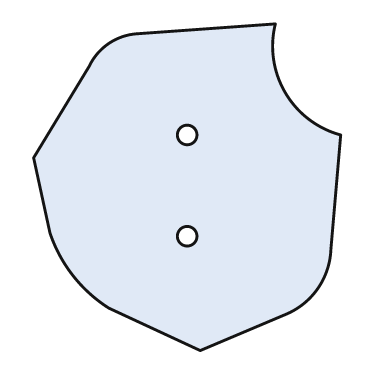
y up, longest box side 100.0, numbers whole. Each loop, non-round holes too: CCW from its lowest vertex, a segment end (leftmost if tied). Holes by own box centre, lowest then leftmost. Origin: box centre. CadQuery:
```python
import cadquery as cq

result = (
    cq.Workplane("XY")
    .moveTo(4.0, -50.0)
    .lineTo(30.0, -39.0)
    .threePointArc((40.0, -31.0), (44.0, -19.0))
    .lineTo(47.0, 16.0)
    .threePointArc((30.0, 29.0), (27.0, 50.0))
    .lineTo(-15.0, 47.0)
    .threePointArc((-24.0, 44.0), (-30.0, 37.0))
    .lineTo(-47.0, 9.0)
    .lineTo(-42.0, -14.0)
    .threePointArc((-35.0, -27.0), (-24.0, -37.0))
    .close()
    .moveTo(0.0, -15.0)
    .circle(3.0)
    .moveTo(0.0, 16.0)
    .circle(3.0)
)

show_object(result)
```